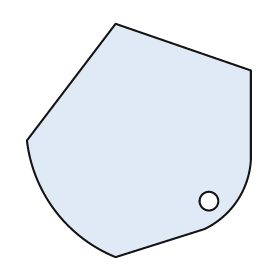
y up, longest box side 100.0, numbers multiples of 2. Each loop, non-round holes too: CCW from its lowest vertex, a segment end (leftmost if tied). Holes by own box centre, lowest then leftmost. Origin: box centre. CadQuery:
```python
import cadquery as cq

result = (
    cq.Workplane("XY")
    .moveTo(-10.0, -50.0)
    .lineTo(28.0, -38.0)
    .threePointArc((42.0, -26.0), (48.0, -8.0))
    .lineTo(48.0, 30.0)
    .lineTo(-10.0, 50.0)
    .lineTo(-48.0, 0.0)
    .threePointArc((-36.0, -30.0), (-10.0, -50.0))
    .close()
    .moveTo(30.0, -26.0)
    .circle(4.0)
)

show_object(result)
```